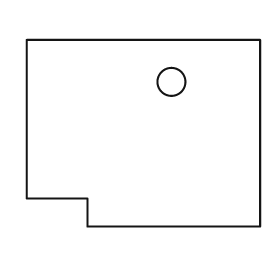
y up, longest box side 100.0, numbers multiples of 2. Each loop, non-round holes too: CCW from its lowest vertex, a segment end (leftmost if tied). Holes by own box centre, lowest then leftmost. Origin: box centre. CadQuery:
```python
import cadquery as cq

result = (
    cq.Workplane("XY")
    .moveTo(-24.0, -40.0)
    .lineTo(50.0, -40.0)
    .lineTo(50.0, 40.0)
    .lineTo(-50.0, 40.0)
    .lineTo(-50.0, -28.0)
    .lineTo(-24.0, -28.0)
    .close()
    .moveTo(12.0, 22.0)
    .circle(6.0)
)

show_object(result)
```